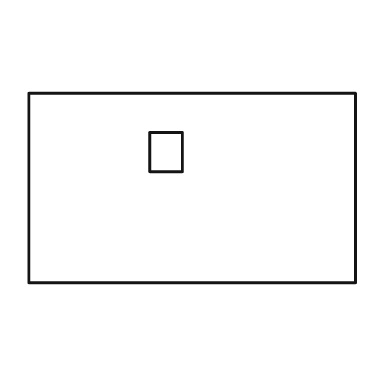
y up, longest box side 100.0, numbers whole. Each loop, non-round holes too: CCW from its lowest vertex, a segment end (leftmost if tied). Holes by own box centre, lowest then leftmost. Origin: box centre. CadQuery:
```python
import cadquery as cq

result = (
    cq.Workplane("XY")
    .moveTo(-50.0, -29.0)
    .lineTo(50.0, -29.0)
    .lineTo(50.0, 29.0)
    .lineTo(-50.0, 29.0)
    .close()
    .moveTo(-13.0, 5.0)
    .lineTo(-3.0, 5.0)
    .lineTo(-3.0, 17.0)
    .lineTo(-13.0, 17.0)
    .close()
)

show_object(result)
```